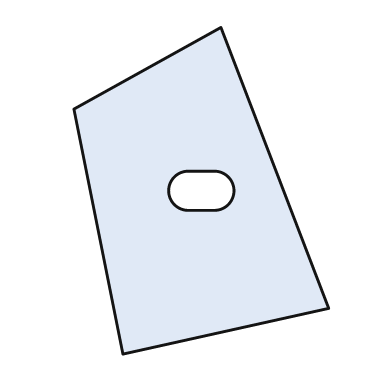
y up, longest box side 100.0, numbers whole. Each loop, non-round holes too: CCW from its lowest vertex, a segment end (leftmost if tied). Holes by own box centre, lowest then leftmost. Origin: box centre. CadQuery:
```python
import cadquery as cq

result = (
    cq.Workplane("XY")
    .moveTo(-24.0, -50.0)
    .lineTo(39.0, -36.0)
    .lineTo(6.0, 50.0)
    .lineTo(-39.0, 25.0)
    .close()
    .moveTo(-4.0, -6.0)
    .lineTo(4.0, -6.0)
    .threePointArc((10.0, 0.0), (4.0, 6.0))
    .lineTo(-4.0, 6.0)
    .threePointArc((-10.0, 0.0), (-4.0, -6.0))
    .close()
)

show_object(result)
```